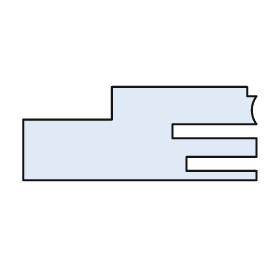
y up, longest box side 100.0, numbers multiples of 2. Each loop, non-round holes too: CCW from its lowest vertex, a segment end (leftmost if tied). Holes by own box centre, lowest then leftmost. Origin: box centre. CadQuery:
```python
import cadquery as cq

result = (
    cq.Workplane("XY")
    .moveTo(-50.0, -20.0)
    .lineTo(50.0, -20.0)
    .lineTo(50.0, -16.0)
    .lineTo(20.0, -16.0)
    .lineTo(20.0, -10.0)
    .lineTo(50.0, -10.0)
    .lineTo(50.0, -2.0)
    .lineTo(14.0, -2.0)
    .lineTo(14.0, 4.0)
    .lineTo(50.0, 4.0)
    .threePointArc((48.0, 10.0), (50.0, 16.0))
    .lineTo(46.0, 16.0)
    .lineTo(46.0, 20.0)
    .lineTo(-12.0, 20.0)
    .lineTo(-12.0, 6.0)
    .lineTo(-50.0, 6.0)
    .close()
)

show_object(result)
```